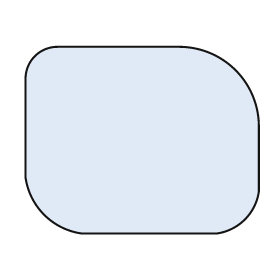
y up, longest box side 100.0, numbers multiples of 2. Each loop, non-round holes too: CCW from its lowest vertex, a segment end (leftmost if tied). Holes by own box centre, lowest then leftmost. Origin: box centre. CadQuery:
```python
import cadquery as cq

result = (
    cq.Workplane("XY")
    .moveTo(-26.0, -40.0)
    .lineTo(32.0, -40.0)
    .threePointArc((44.0, -34.0), (50.0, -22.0))
    .lineTo(50.0, 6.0)
    .threePointArc((40.0, 30.0), (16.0, 40.0))
    .lineTo(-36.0, 40.0)
    .threePointArc((-46.0, 36.0), (-50.0, 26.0))
    .lineTo(-50.0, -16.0)
    .threePointArc((-42.0, -32.0), (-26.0, -40.0))
    .close()
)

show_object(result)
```